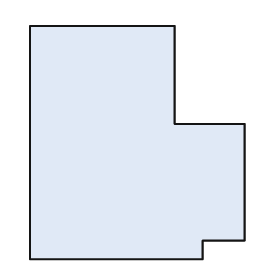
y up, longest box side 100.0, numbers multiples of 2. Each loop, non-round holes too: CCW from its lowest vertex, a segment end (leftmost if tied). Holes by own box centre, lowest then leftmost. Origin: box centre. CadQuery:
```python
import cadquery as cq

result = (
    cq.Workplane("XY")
    .moveTo(-46.0, -50.0)
    .lineTo(28.0, -50.0)
    .lineTo(28.0, -42.0)
    .lineTo(46.0, -42.0)
    .lineTo(46.0, 8.0)
    .lineTo(16.0, 8.0)
    .lineTo(16.0, 50.0)
    .lineTo(-46.0, 50.0)
    .close()
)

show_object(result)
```